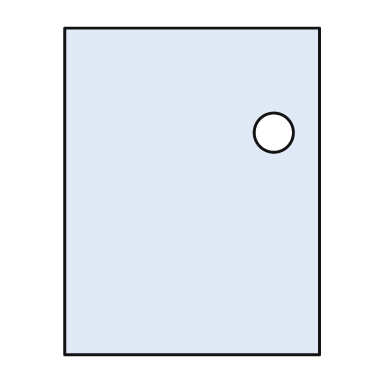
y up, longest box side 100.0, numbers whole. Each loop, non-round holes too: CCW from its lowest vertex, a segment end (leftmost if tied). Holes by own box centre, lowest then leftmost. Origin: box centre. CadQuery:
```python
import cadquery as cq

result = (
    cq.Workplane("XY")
    .moveTo(-39.0, -50.0)
    .lineTo(39.0, -50.0)
    .lineTo(39.0, 50.0)
    .lineTo(-39.0, 50.0)
    .close()
    .moveTo(25.0, 18.0)
    .circle(6.0)
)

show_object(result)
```